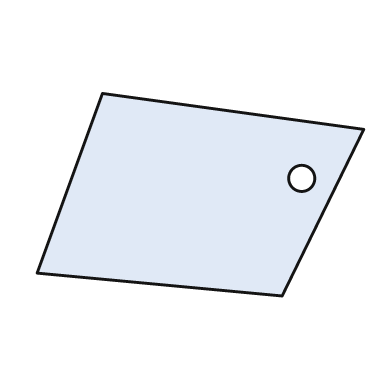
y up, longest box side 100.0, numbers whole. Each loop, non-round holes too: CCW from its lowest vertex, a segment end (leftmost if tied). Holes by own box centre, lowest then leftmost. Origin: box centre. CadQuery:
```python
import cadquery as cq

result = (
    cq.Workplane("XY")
    .moveTo(25.0, -31.0)
    .lineTo(50.0, 20.0)
    .lineTo(-30.0, 31.0)
    .lineTo(-50.0, -24.0)
    .close()
    .moveTo(31.0, 5.0)
    .circle(4.0)
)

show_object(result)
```